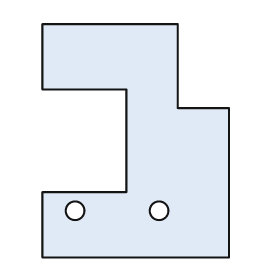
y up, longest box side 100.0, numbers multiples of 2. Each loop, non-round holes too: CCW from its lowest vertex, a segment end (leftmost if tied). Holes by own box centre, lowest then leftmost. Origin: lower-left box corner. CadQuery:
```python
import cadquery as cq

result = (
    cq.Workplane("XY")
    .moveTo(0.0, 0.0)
    .lineTo(80.0, 0.0)
    .lineTo(80.0, 64.0)
    .lineTo(58.0, 64.0)
    .lineTo(58.0, 100.0)
    .lineTo(0.0, 100.0)
    .lineTo(0.0, 72.0)
    .lineTo(36.0, 72.0)
    .lineTo(36.0, 28.0)
    .lineTo(0.0, 28.0)
    .close()
    .moveTo(14.0, 20.0)
    .circle(4.0)
    .moveTo(50.0, 20.0)
    .circle(4.0)
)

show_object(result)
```